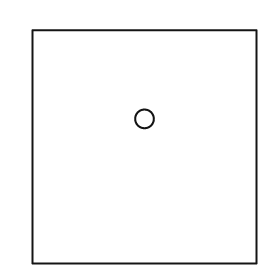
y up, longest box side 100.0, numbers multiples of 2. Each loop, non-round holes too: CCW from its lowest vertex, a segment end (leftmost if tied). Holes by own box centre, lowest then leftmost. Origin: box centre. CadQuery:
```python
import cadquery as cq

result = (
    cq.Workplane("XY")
    .moveTo(-48.0, -50.0)
    .lineTo(48.0, -50.0)
    .lineTo(48.0, 50.0)
    .lineTo(-48.0, 50.0)
    .close()
    .moveTo(0.0, 12.0)
    .circle(4.0)
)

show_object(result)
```